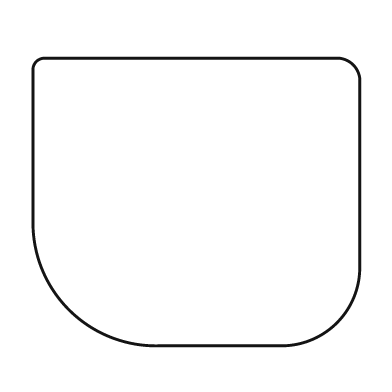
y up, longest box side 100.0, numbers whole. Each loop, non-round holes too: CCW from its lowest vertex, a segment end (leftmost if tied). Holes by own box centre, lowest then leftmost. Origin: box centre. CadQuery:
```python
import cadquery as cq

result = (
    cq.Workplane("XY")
    .moveTo(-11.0, -44.0)
    .lineTo(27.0, -44.0)
    .threePointArc((43.0, -37.0), (50.0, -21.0))
    .lineTo(50.0, 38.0)
    .threePointArc((48.0, 42.0), (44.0, 44.0))
    .lineTo(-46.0, 44.0)
    .threePointArc((-49.0, 43.0), (-50.0, 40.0))
    .lineTo(-50.0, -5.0)
    .threePointArc((-39.0, -33.0), (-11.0, -44.0))
    .close()
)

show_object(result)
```